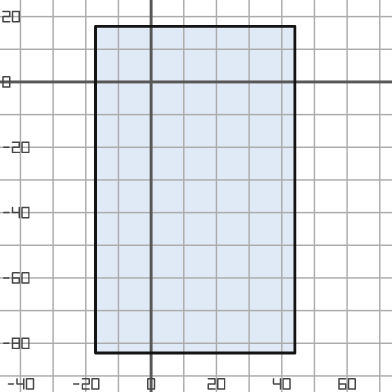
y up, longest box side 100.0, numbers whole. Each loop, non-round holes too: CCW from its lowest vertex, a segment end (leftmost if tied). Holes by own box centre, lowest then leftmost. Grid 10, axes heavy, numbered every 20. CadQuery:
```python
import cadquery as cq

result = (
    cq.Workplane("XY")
    .moveTo(-17.0, -83.0)
    .lineTo(44.0, -83.0)
    .lineTo(44.0, 17.0)
    .lineTo(-17.0, 17.0)
    .close()
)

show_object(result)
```